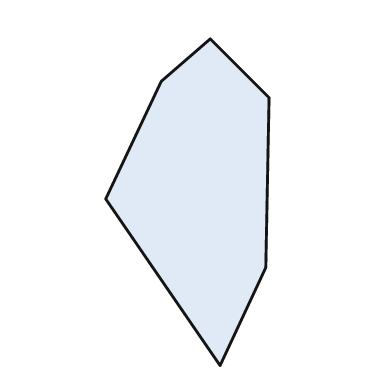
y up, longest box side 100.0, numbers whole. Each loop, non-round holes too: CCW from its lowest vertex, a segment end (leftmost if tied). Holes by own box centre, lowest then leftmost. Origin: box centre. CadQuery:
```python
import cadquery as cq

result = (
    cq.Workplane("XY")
    .moveTo(10.0, -50.0)
    .lineTo(24.0, -20.0)
    .lineTo(25.0, 32.0)
    .lineTo(7.0, 50.0)
    .lineTo(-8.0, 37.0)
    .lineTo(-25.0, 1.0)
    .close()
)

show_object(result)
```